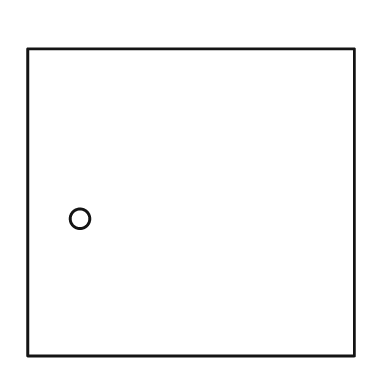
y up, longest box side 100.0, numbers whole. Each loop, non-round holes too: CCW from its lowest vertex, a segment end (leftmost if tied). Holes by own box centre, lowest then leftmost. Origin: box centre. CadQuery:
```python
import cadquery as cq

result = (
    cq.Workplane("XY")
    .moveTo(-50.0, -47.0)
    .lineTo(50.0, -47.0)
    .lineTo(50.0, 47.0)
    .lineTo(-50.0, 47.0)
    .close()
    .moveTo(-34.0, -5.0)
    .circle(3.0)
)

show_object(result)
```